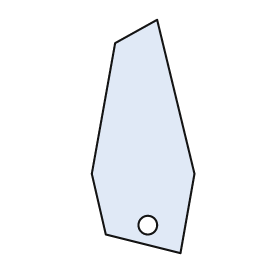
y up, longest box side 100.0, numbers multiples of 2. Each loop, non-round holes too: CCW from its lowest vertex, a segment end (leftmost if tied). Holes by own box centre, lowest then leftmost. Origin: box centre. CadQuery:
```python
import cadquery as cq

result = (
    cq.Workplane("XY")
    .moveTo(16.0, -50.0)
    .lineTo(22.0, -16.0)
    .lineTo(6.0, 50.0)
    .lineTo(-12.0, 40.0)
    .lineTo(-22.0, -16.0)
    .lineTo(-16.0, -42.0)
    .close()
    .moveTo(2.0, -38.0)
    .circle(4.0)
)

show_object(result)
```